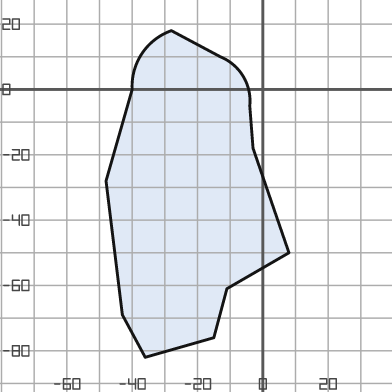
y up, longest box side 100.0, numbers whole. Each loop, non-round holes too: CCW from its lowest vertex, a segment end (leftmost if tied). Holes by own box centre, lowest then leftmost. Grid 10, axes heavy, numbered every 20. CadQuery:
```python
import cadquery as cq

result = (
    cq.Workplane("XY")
    .moveTo(-36.0, -82.0)
    .lineTo(-15.0, -76.0)
    .lineTo(-11.0, -61.0)
    .lineTo(8.0, -50.0)
    .lineTo(-3.0, -18.0)
    .lineTo(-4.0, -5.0)
    .threePointArc((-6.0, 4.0), (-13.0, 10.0))
    .lineTo(-28.0, 18.0)
    .threePointArc((-37.0, 11.0), (-40.0, 0.0))
    .lineTo(-48.0, -28.0)
    .lineTo(-43.0, -69.0)
    .close()
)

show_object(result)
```